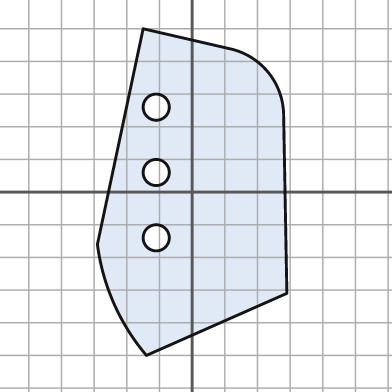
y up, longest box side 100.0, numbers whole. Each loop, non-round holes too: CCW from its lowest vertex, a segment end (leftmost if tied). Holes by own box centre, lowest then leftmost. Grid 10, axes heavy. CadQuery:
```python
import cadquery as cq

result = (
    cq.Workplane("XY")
    .moveTo(-14.0, -50.0)
    .lineTo(29.0, -31.0)
    .lineTo(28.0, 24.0)
    .threePointArc((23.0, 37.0), (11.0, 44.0))
    .lineTo(-15.0, 50.0)
    .lineTo(-29.0, -16.0)
    .threePointArc((-24.0, -34.0), (-14.0, -50.0))
    .close()
    .moveTo(-11.0, -14.0)
    .circle(4.0)
    .moveTo(-11.0, 6.0)
    .circle(4.0)
    .moveTo(-11.0, 26.0)
    .circle(4.0)
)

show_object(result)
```